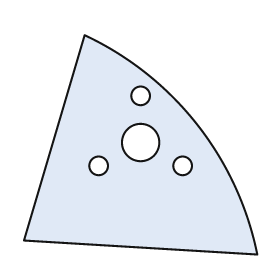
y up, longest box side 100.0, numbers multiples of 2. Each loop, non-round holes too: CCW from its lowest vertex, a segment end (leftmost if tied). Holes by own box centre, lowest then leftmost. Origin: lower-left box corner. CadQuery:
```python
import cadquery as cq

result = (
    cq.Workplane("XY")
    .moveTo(100.0, 0.0)
    .threePointArc((74.0, 56.0), (26.0, 94.0))
    .lineTo(0.0, 6.0)
    .close()
    .moveTo(32.0, 38.0)
    .circle(4.0)
    .moveTo(68.0, 38.0)
    .circle(4.0)
    .moveTo(50.0, 48.0)
    .circle(8.0)
    .moveTo(50.0, 68.0)
    .circle(4.0)
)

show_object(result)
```